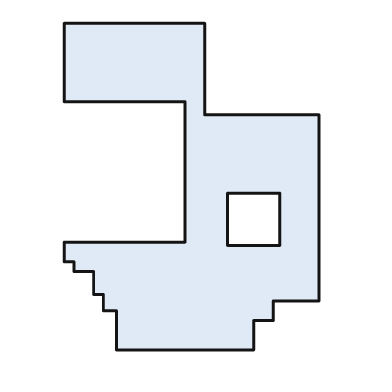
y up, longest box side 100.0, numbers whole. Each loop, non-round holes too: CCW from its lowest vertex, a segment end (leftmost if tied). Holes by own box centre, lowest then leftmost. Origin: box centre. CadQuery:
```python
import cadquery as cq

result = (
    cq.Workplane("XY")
    .moveTo(-23.0, -50.0)
    .lineTo(19.0, -50.0)
    .lineTo(19.0, -41.0)
    .lineTo(25.0, -41.0)
    .lineTo(25.0, -35.0)
    .lineTo(39.0, -35.0)
    .lineTo(39.0, 22.0)
    .lineTo(4.0, 22.0)
    .lineTo(4.0, 50.0)
    .lineTo(-39.0, 50.0)
    .lineTo(-39.0, 26.0)
    .lineTo(-2.0, 26.0)
    .lineTo(-2.0, -17.0)
    .lineTo(-39.0, -17.0)
    .lineTo(-39.0, -23.0)
    .lineTo(-36.0, -23.0)
    .lineTo(-36.0, -26.0)
    .lineTo(-30.0, -26.0)
    .lineTo(-30.0, -33.0)
    .lineTo(-27.0, -33.0)
    .lineTo(-27.0, -38.0)
    .lineTo(-23.0, -38.0)
    .close()
    .moveTo(11.0, -18.0)
    .lineTo(27.0, -18.0)
    .lineTo(27.0, -2.0)
    .lineTo(11.0, -2.0)
    .close()
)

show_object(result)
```